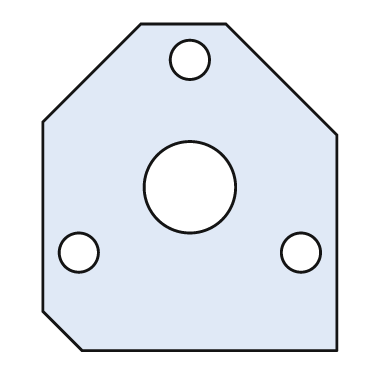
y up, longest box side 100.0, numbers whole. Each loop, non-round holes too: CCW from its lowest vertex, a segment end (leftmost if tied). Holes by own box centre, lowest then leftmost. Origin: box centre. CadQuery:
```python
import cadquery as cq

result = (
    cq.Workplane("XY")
    .moveTo(-33.0, -50.0)
    .lineTo(45.0, -50.0)
    .lineTo(45.0, 16.0)
    .lineTo(11.0, 50.0)
    .lineTo(-15.0, 50.0)
    .lineTo(-45.0, 20.0)
    .lineTo(-45.0, -38.0)
    .close()
    .moveTo(-34.0, -20.0)
    .circle(6.0)
    .moveTo(34.0, -20.0)
    .circle(6.0)
    .moveTo(0.0, 0.0)
    .circle(14.0)
    .moveTo(0.0, 39.0)
    .circle(6.0)
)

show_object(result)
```